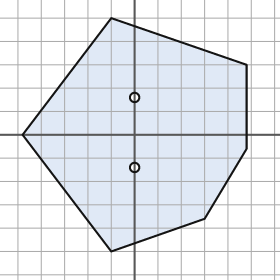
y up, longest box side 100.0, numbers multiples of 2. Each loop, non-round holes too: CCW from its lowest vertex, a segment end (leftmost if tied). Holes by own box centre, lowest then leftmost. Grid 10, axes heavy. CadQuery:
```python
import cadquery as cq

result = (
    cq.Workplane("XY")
    .moveTo(-10.0, -50.0)
    .lineTo(30.0, -36.0)
    .lineTo(48.0, -6.0)
    .lineTo(48.0, 30.0)
    .lineTo(-10.0, 50.0)
    .lineTo(-48.0, 0.0)
    .close()
    .moveTo(0.0, -14.0)
    .circle(2.0)
    .moveTo(0.0, 16.0)
    .circle(2.0)
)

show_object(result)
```